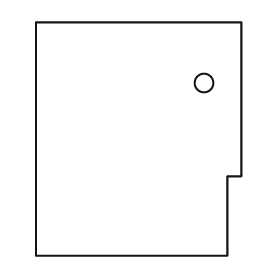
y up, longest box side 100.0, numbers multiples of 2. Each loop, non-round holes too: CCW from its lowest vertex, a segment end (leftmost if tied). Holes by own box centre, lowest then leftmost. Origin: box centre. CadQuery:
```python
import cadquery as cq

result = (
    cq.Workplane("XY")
    .moveTo(-44.0, -50.0)
    .lineTo(38.0, -50.0)
    .lineTo(38.0, -16.0)
    .lineTo(44.0, -16.0)
    .lineTo(44.0, 50.0)
    .lineTo(-44.0, 50.0)
    .close()
    .moveTo(28.0, 24.0)
    .circle(4.0)
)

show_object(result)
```